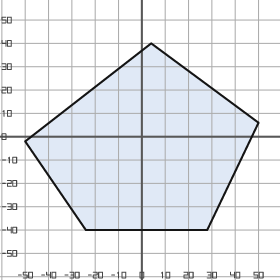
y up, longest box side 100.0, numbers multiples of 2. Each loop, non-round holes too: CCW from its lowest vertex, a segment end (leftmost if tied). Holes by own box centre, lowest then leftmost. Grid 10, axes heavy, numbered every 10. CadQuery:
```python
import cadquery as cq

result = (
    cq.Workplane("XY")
    .moveTo(-24.0, -40.0)
    .lineTo(28.0, -40.0)
    .lineTo(50.0, 6.0)
    .lineTo(4.0, 40.0)
    .lineTo(-50.0, -2.0)
    .close()
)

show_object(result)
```